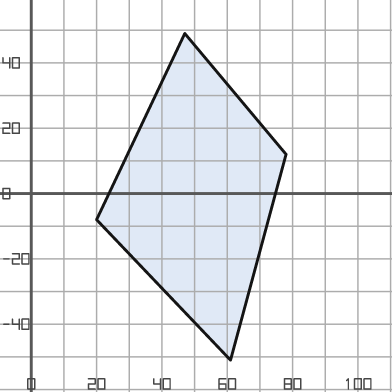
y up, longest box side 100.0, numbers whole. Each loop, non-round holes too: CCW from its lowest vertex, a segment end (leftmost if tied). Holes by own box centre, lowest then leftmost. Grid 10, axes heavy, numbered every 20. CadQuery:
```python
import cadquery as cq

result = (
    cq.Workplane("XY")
    .moveTo(61.0, -51.0)
    .lineTo(78.0, 12.0)
    .lineTo(47.0, 49.0)
    .lineTo(20.0, -8.0)
    .close()
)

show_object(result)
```